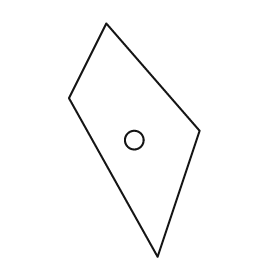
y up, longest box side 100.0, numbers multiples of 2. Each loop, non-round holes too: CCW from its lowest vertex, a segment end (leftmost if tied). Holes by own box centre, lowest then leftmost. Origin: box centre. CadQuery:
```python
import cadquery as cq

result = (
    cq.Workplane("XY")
    .moveTo(10.0, -50.0)
    .lineTo(28.0, 4.0)
    .lineTo(-12.0, 50.0)
    .lineTo(-28.0, 18.0)
    .close()
    .moveTo(0.0, 0.0)
    .circle(4.0)
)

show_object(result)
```